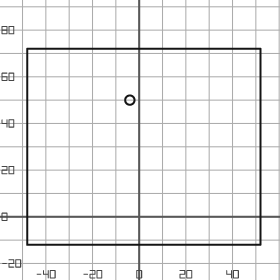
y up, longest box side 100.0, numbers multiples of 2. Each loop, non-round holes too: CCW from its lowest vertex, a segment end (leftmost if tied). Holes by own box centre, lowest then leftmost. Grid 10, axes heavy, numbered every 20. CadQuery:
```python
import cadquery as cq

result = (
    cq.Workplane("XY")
    .moveTo(-48.0, -12.0)
    .lineTo(52.0, -12.0)
    .lineTo(52.0, 72.0)
    .lineTo(-48.0, 72.0)
    .close()
    .moveTo(-4.0, 50.0)
    .circle(2.0)
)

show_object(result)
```